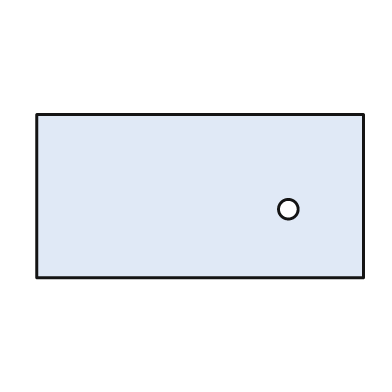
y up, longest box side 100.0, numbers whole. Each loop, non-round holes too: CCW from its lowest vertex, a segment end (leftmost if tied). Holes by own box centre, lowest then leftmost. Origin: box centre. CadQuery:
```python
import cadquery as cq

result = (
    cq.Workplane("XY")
    .moveTo(-50.0, -25.0)
    .lineTo(50.0, -25.0)
    .lineTo(50.0, 25.0)
    .lineTo(-50.0, 25.0)
    .close()
    .moveTo(27.0, -4.0)
    .circle(3.0)
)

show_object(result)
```